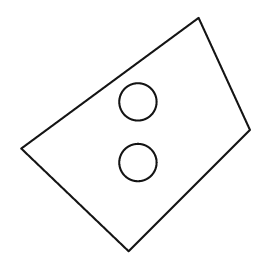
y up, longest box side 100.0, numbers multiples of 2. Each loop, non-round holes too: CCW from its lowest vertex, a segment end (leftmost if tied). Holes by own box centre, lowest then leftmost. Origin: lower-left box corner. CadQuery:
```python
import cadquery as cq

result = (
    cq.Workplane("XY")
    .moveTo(46.0, 0.0)
    .lineTo(98.0, 52.0)
    .lineTo(76.0, 100.0)
    .lineTo(0.0, 44.0)
    .close()
    .moveTo(50.0, 38.0)
    .circle(8.0)
    .moveTo(50.0, 64.0)
    .circle(8.0)
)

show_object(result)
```